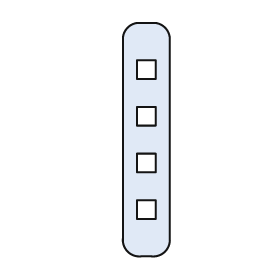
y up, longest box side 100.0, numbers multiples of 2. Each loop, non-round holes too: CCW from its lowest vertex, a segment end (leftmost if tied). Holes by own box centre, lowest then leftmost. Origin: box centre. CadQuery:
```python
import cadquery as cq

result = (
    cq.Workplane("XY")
    .moveTo(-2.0, -50.0)
    .lineTo(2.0, -50.0)
    .threePointArc((8.0, -48.0), (10.0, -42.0))
    .lineTo(10.0, 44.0)
    .threePointArc((8.0, 48.0), (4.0, 50.0))
    .lineTo(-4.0, 50.0)
    .threePointArc((-8.0, 48.0), (-10.0, 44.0))
    .lineTo(-10.0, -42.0)
    .threePointArc((-8.0, -48.0), (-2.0, -50.0))
    .close()
    .moveTo(-4.0, -34.0)
    .lineTo(4.0, -34.0)
    .lineTo(4.0, -26.0)
    .lineTo(-4.0, -26.0)
    .close()
    .moveTo(-4.0, -14.0)
    .lineTo(4.0, -14.0)
    .lineTo(4.0, -6.0)
    .lineTo(-4.0, -6.0)
    .close()
    .moveTo(-4.0, 6.0)
    .lineTo(4.0, 6.0)
    .lineTo(4.0, 14.0)
    .lineTo(-4.0, 14.0)
    .close()
    .moveTo(-4.0, 26.0)
    .lineTo(4.0, 26.0)
    .lineTo(4.0, 34.0)
    .lineTo(-4.0, 34.0)
    .close()
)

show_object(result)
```